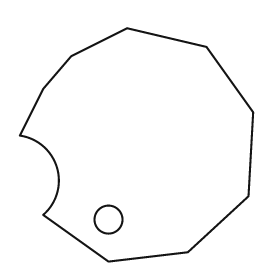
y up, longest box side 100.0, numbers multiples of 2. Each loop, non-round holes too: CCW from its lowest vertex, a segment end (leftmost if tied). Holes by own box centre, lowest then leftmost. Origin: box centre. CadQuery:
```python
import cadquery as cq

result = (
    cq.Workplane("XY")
    .moveTo(-12.0, -50.0)
    .lineTo(22.0, -46.0)
    .lineTo(48.0, -22.0)
    .lineTo(50.0, 14.0)
    .lineTo(30.0, 42.0)
    .lineTo(-4.0, 50.0)
    .lineTo(-28.0, 38.0)
    .lineTo(-40.0, 24.0)
    .lineTo(-50.0, 4.0)
    .threePointArc((-34.0, -10.0), (-40.0, -30.0))
    .close()
    .moveTo(-12.0, -32.0)
    .circle(6.0)
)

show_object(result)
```